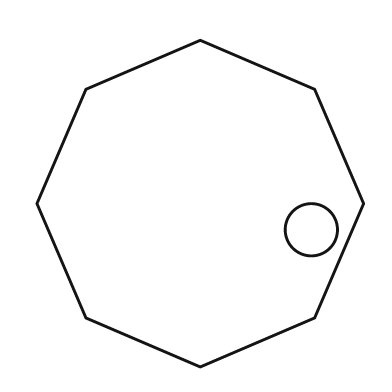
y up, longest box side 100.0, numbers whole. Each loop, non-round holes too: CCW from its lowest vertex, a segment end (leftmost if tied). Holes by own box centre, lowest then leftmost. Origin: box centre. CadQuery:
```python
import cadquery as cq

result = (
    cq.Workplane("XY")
    .moveTo(0.0, -50.0)
    .lineTo(35.0, -35.0)
    .lineTo(50.0, 0.0)
    .lineTo(35.0, 35.0)
    .lineTo(0.0, 50.0)
    .lineTo(-35.0, 35.0)
    .lineTo(-50.0, 0.0)
    .lineTo(-35.0, -35.0)
    .close()
    .moveTo(34.0, -8.0)
    .circle(8.0)
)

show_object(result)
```